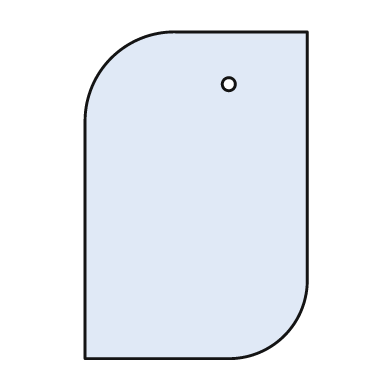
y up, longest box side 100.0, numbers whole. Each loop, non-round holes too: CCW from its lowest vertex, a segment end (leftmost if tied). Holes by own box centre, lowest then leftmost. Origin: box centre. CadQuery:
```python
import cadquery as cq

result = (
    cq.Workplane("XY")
    .moveTo(-34.0, -50.0)
    .lineTo(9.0, -50.0)
    .threePointArc((27.0, -43.0), (34.0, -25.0))
    .lineTo(34.0, 50.0)
    .lineTo(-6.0, 50.0)
    .threePointArc((-26.0, 42.0), (-34.0, 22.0))
    .close()
    .moveTo(10.0, 34.0)
    .circle(2.0)
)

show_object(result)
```